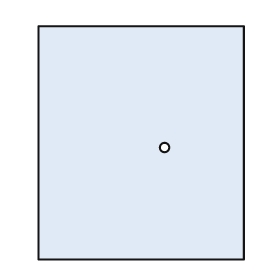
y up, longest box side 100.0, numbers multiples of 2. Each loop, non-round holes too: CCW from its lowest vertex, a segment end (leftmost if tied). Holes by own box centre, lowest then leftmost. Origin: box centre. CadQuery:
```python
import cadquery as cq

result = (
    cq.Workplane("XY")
    .moveTo(-44.0, -50.0)
    .lineTo(44.0, -50.0)
    .lineTo(44.0, 50.0)
    .lineTo(-44.0, 50.0)
    .close()
    .moveTo(10.0, -2.0)
    .circle(2.0)
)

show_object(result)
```